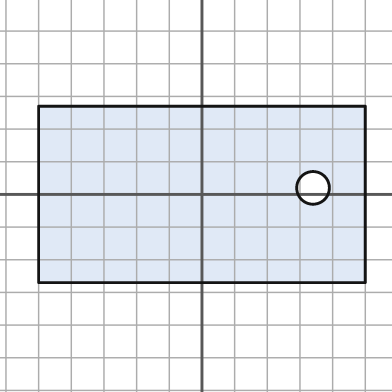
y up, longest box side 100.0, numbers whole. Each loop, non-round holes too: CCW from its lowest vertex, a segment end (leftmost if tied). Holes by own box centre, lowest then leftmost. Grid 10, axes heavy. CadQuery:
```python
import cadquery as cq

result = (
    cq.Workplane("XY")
    .moveTo(-50.0, -27.0)
    .lineTo(50.0, -27.0)
    .lineTo(50.0, 27.0)
    .lineTo(-50.0, 27.0)
    .close()
    .moveTo(34.0, 2.0)
    .circle(5.0)
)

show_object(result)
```